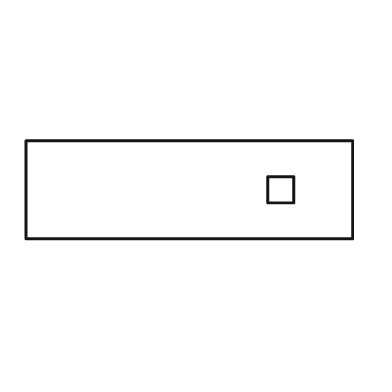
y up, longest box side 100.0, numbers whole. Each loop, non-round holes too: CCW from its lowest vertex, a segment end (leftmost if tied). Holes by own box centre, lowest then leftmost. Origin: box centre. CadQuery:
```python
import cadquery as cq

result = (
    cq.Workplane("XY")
    .moveTo(-50.0, -15.0)
    .lineTo(50.0, -15.0)
    .lineTo(50.0, 15.0)
    .lineTo(-50.0, 15.0)
    .close()
    .moveTo(24.0, -4.0)
    .lineTo(32.0, -4.0)
    .lineTo(32.0, 4.0)
    .lineTo(24.0, 4.0)
    .close()
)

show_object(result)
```